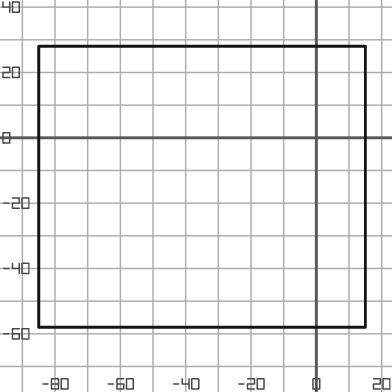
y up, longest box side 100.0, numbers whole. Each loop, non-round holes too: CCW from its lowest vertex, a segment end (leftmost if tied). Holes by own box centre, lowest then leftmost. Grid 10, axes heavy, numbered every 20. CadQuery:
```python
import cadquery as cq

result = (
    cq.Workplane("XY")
    .moveTo(-85.0, -58.0)
    .lineTo(15.0, -58.0)
    .lineTo(15.0, 28.0)
    .lineTo(-85.0, 28.0)
    .close()
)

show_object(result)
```